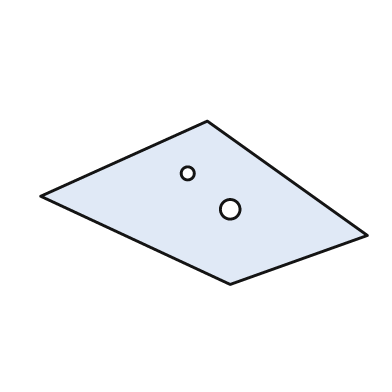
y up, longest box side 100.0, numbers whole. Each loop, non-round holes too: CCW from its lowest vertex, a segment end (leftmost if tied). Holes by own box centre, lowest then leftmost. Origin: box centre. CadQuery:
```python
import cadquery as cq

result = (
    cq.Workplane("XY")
    .moveTo(8.0, -25.0)
    .lineTo(50.0, -10.0)
    .lineTo(1.0, 25.0)
    .lineTo(-50.0, 2.0)
    .close()
    .moveTo(8.0, -2.0)
    .circle(3.0)
    .moveTo(-5.0, 9.0)
    .circle(2.0)
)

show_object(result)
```